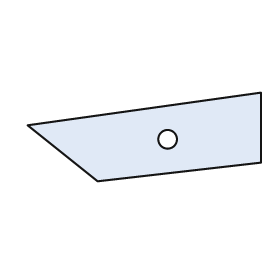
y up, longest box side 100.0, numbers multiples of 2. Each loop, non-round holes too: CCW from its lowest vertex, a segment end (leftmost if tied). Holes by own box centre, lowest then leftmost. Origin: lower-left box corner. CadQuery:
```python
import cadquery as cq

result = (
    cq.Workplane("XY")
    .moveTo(30.0, 0.0)
    .lineTo(100.0, 8.0)
    .lineTo(100.0, 38.0)
    .lineTo(0.0, 24.0)
    .close()
    .moveTo(60.0, 18.0)
    .circle(4.0)
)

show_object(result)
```